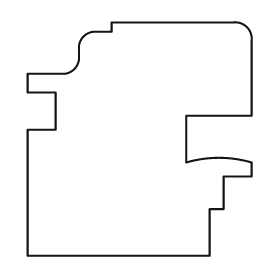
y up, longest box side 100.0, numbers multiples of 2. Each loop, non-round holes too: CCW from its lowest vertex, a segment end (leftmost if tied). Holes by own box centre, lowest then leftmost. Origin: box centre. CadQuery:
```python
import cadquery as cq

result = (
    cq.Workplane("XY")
    .moveTo(-48.0, -50.0)
    .lineTo(30.0, -50.0)
    .lineTo(30.0, -30.0)
    .lineTo(36.0, -30.0)
    .lineTo(36.0, -16.0)
    .lineTo(48.0, -16.0)
    .lineTo(48.0, -10.0)
    .threePointArc((34.0, -8.0), (20.0, -10.0))
    .lineTo(20.0, 10.0)
    .lineTo(48.0, 10.0)
    .lineTo(48.0, 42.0)
    .threePointArc((46.0, 48.0), (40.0, 50.0))
    .lineTo(-12.0, 50.0)
    .lineTo(-12.0, 46.0)
    .lineTo(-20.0, 46.0)
    .threePointArc((-24.0, 44.0), (-26.0, 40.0))
    .lineTo(-26.0, 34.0)
    .threePointArc((-28.0, 30.0), (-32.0, 28.0))
    .lineTo(-48.0, 28.0)
    .lineTo(-48.0, 20.0)
    .lineTo(-36.0, 20.0)
    .lineTo(-36.0, 4.0)
    .lineTo(-48.0, 4.0)
    .close()
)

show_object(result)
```